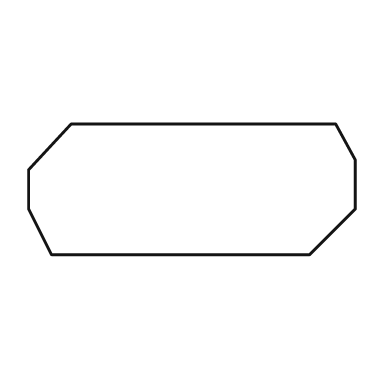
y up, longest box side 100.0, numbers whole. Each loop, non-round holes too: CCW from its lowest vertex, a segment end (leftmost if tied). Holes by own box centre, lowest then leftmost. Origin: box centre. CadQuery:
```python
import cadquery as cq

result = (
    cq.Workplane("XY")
    .moveTo(-43.0, -20.0)
    .lineTo(36.0, -20.0)
    .lineTo(50.0, -6.0)
    .lineTo(50.0, 9.0)
    .lineTo(44.0, 20.0)
    .lineTo(-37.0, 20.0)
    .lineTo(-50.0, 6.0)
    .lineTo(-50.0, -6.0)
    .close()
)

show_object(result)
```